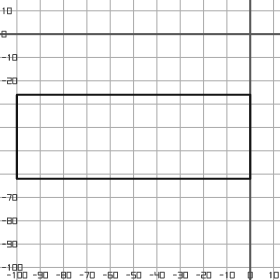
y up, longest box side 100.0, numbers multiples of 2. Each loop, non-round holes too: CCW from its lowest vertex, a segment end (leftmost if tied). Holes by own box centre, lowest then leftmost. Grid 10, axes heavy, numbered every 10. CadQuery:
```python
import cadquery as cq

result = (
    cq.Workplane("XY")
    .moveTo(-100.0, -62.0)
    .lineTo(0.0, -62.0)
    .lineTo(0.0, -26.0)
    .lineTo(-100.0, -26.0)
    .close()
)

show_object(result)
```